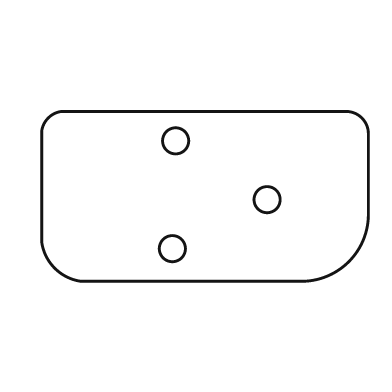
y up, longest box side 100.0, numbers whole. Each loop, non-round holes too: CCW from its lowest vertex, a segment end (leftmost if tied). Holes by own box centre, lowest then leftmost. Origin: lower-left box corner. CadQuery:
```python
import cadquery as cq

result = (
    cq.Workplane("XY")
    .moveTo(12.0, 0.0)
    .lineTo(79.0, 0.0)
    .threePointArc((94.0, 6.0), (100.0, 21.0))
    .lineTo(100.0, 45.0)
    .threePointArc((98.0, 50.0), (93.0, 52.0))
    .lineTo(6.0, 52.0)
    .threePointArc((2.0, 50.0), (0.0, 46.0))
    .lineTo(0.0, 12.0)
    .threePointArc((4.0, 4.0), (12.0, 0.0))
    .close()
    .moveTo(40.0, 10.0)
    .circle(4.0)
    .moveTo(69.0, 25.0)
    .circle(4.0)
    .moveTo(41.0, 43.0)
    .circle(4.0)
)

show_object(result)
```